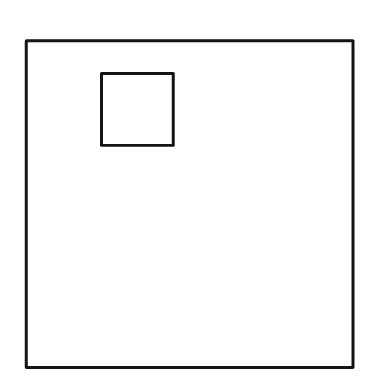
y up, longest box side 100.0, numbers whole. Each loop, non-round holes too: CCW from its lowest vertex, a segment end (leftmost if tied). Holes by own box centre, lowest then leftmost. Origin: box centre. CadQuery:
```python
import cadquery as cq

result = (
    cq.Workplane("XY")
    .moveTo(-50.0, -50.0)
    .lineTo(50.0, -50.0)
    .lineTo(50.0, 50.0)
    .lineTo(-50.0, 50.0)
    .close()
    .moveTo(-27.0, 18.0)
    .lineTo(-5.0, 18.0)
    .lineTo(-5.0, 40.0)
    .lineTo(-27.0, 40.0)
    .close()
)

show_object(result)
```